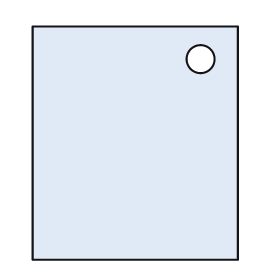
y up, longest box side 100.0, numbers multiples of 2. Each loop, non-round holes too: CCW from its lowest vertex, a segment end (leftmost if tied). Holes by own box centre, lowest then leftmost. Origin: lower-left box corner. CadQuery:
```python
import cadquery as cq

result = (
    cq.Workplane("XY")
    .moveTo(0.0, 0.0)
    .lineTo(88.0, 0.0)
    .lineTo(88.0, 100.0)
    .lineTo(0.0, 100.0)
    .close()
    .moveTo(72.0, 86.0)
    .circle(6.0)
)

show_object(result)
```